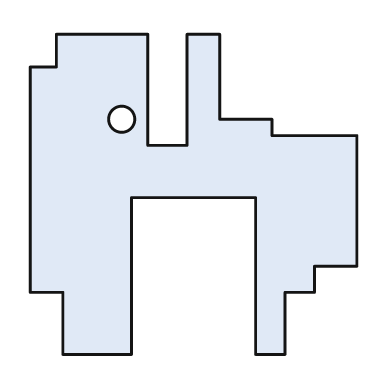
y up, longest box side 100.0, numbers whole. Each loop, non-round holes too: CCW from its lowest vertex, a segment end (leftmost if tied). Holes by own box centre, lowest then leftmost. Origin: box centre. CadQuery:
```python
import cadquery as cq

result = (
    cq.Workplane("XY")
    .moveTo(-40.0, -49.0)
    .lineTo(-19.0, -49.0)
    .lineTo(-19.0, -1.0)
    .lineTo(19.0, -1.0)
    .lineTo(19.0, -49.0)
    .lineTo(28.0, -49.0)
    .lineTo(28.0, -30.0)
    .lineTo(37.0, -30.0)
    .lineTo(37.0, -22.0)
    .lineTo(50.0, -22.0)
    .lineTo(50.0, 18.0)
    .lineTo(24.0, 18.0)
    .lineTo(24.0, 23.0)
    .lineTo(8.0, 23.0)
    .lineTo(8.0, 49.0)
    .lineTo(-2.0, 49.0)
    .lineTo(-2.0, 15.0)
    .lineTo(-14.0, 15.0)
    .lineTo(-14.0, 49.0)
    .lineTo(-42.0, 49.0)
    .lineTo(-42.0, 39.0)
    .lineTo(-50.0, 39.0)
    .lineTo(-50.0, -30.0)
    .lineTo(-40.0, -30.0)
    .close()
    .moveTo(-22.0, 23.0)
    .circle(4.0)
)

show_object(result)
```